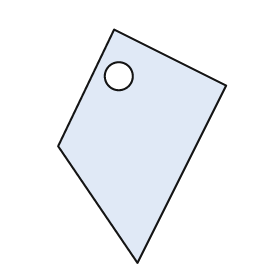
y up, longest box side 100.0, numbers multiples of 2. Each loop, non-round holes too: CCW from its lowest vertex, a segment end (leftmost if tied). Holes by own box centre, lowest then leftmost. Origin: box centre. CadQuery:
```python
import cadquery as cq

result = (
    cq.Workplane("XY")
    .moveTo(-2.0, -50.0)
    .lineTo(36.0, 26.0)
    .lineTo(-12.0, 50.0)
    .lineTo(-36.0, 0.0)
    .close()
    .moveTo(-10.0, 30.0)
    .circle(6.0)
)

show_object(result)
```